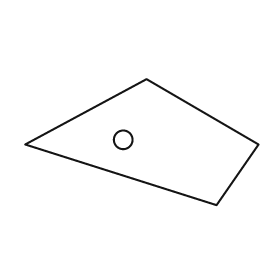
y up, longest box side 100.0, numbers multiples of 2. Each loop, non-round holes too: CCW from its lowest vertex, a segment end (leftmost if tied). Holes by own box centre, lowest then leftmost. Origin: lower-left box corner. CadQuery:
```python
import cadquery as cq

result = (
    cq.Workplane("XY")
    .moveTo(82.0, 0.0)
    .lineTo(100.0, 26.0)
    .lineTo(52.0, 54.0)
    .lineTo(0.0, 26.0)
    .close()
    .moveTo(42.0, 28.0)
    .circle(4.0)
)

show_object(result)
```